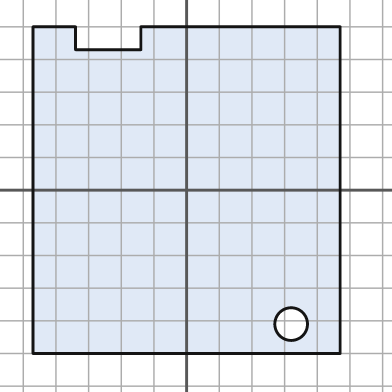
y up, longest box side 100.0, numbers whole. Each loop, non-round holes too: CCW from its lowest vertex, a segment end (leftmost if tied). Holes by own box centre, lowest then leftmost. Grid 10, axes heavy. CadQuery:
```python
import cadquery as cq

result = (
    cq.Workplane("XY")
    .moveTo(-47.0, -50.0)
    .lineTo(47.0, -50.0)
    .lineTo(47.0, 50.0)
    .lineTo(-14.0, 50.0)
    .lineTo(-14.0, 43.0)
    .lineTo(-34.0, 43.0)
    .lineTo(-34.0, 50.0)
    .lineTo(-47.0, 50.0)
    .close()
    .moveTo(32.0, -41.0)
    .circle(5.0)
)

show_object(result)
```